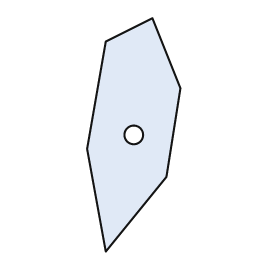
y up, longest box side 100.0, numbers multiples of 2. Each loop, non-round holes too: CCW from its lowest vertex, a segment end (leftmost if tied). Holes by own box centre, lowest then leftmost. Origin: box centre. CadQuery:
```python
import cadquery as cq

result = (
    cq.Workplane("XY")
    .moveTo(-12.0, -50.0)
    .lineTo(14.0, -18.0)
    .lineTo(20.0, 20.0)
    .lineTo(8.0, 50.0)
    .lineTo(-12.0, 40.0)
    .lineTo(-20.0, -6.0)
    .close()
    .moveTo(0.0, 0.0)
    .circle(4.0)
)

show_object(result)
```